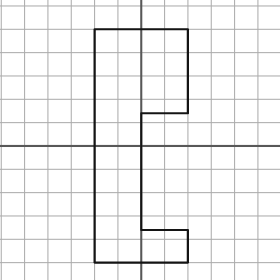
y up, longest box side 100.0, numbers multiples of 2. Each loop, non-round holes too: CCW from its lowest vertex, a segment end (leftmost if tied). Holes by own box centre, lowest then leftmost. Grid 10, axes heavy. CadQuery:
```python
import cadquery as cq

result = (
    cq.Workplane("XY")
    .moveTo(-20.0, -50.0)
    .lineTo(20.0, -50.0)
    .lineTo(20.0, -36.0)
    .lineTo(0.0, -36.0)
    .lineTo(0.0, 14.0)
    .lineTo(20.0, 14.0)
    .lineTo(20.0, 50.0)
    .lineTo(-20.0, 50.0)
    .close()
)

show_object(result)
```